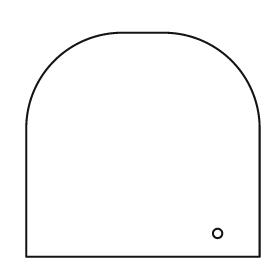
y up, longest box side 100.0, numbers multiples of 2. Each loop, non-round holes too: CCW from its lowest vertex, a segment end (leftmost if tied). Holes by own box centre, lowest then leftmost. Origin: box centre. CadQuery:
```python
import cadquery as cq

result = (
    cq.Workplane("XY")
    .moveTo(-50.0, -48.0)
    .lineTo(50.0, -48.0)
    .lineTo(50.0, 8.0)
    .threePointArc((38.0, 36.0), (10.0, 48.0))
    .lineTo(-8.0, 48.0)
    .threePointArc((-38.0, 36.0), (-50.0, 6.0))
    .close()
    .moveTo(32.0, -38.0)
    .circle(2.0)
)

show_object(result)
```